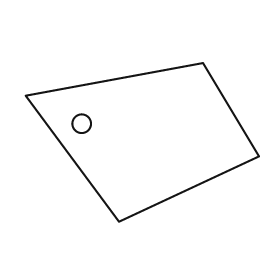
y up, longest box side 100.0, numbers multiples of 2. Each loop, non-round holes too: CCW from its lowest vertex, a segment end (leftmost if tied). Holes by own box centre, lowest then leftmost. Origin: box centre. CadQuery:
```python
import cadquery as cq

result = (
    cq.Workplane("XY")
    .moveTo(-10.0, -34.0)
    .lineTo(50.0, -6.0)
    .lineTo(26.0, 34.0)
    .lineTo(-50.0, 20.0)
    .close()
    .moveTo(-26.0, 8.0)
    .circle(4.0)
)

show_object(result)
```